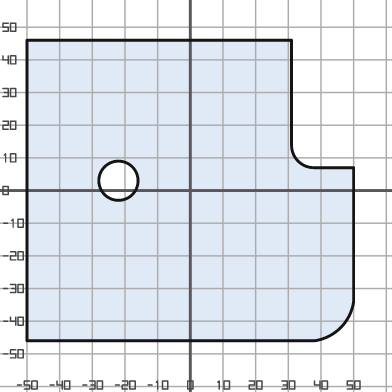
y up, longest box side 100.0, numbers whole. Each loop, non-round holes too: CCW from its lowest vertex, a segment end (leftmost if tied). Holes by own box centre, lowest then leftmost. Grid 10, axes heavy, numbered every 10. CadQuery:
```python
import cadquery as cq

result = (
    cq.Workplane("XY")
    .moveTo(-50.0, -46.0)
    .lineTo(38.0, -46.0)
    .threePointArc((46.0, -42.0), (50.0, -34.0))
    .lineTo(50.0, 7.0)
    .lineTo(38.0, 7.0)
    .threePointArc((33.0, 9.0), (31.0, 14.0))
    .lineTo(31.0, 46.0)
    .lineTo(-50.0, 46.0)
    .close()
    .moveTo(-22.0, 3.0)
    .circle(6.0)
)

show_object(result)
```